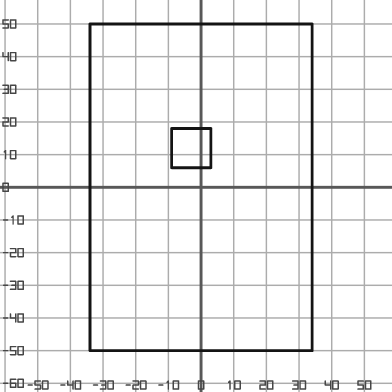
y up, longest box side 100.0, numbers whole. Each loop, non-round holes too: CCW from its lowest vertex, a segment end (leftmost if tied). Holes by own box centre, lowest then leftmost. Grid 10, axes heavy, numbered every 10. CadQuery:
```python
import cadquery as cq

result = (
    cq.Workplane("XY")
    .moveTo(-34.0, -50.0)
    .lineTo(34.0, -50.0)
    .lineTo(34.0, 50.0)
    .lineTo(-34.0, 50.0)
    .close()
    .moveTo(-9.0, 6.0)
    .lineTo(3.0, 6.0)
    .lineTo(3.0, 18.0)
    .lineTo(-9.0, 18.0)
    .close()
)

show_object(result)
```